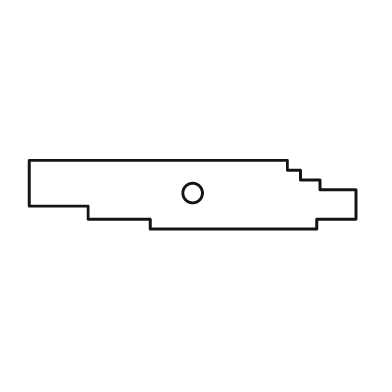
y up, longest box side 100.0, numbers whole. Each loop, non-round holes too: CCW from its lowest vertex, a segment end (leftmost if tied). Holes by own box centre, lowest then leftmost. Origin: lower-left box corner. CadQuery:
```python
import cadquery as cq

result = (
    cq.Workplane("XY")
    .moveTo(37.0, 0.0)
    .lineTo(88.0, 0.0)
    .lineTo(88.0, 3.0)
    .lineTo(100.0, 3.0)
    .lineTo(100.0, 12.0)
    .lineTo(89.0, 12.0)
    .lineTo(89.0, 15.0)
    .lineTo(83.0, 15.0)
    .lineTo(83.0, 18.0)
    .lineTo(79.0, 18.0)
    .lineTo(79.0, 21.0)
    .lineTo(0.0, 21.0)
    .lineTo(0.0, 7.0)
    .lineTo(18.0, 7.0)
    .lineTo(18.0, 3.0)
    .lineTo(37.0, 3.0)
    .close()
    .moveTo(50.0, 11.0)
    .circle(3.0)
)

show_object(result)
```